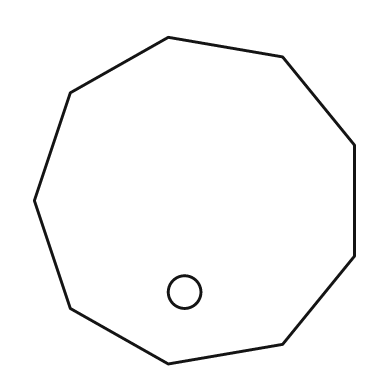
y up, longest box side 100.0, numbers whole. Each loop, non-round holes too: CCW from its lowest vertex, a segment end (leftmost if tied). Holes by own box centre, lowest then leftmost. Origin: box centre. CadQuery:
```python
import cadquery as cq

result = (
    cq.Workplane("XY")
    .moveTo(-8.0, -50.0)
    .lineTo(27.0, -44.0)
    .lineTo(49.0, -17.0)
    .lineTo(49.0, 17.0)
    .lineTo(27.0, 44.0)
    .lineTo(-8.0, 50.0)
    .lineTo(-38.0, 33.0)
    .lineTo(-49.0, 0.0)
    .lineTo(-38.0, -33.0)
    .close()
    .moveTo(-3.0, -28.0)
    .circle(5.0)
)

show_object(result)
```